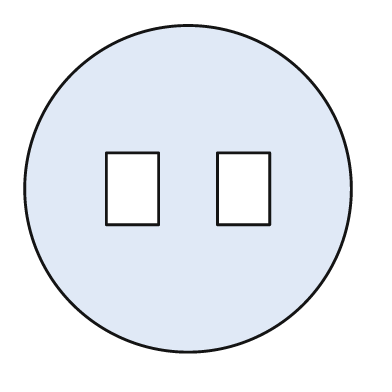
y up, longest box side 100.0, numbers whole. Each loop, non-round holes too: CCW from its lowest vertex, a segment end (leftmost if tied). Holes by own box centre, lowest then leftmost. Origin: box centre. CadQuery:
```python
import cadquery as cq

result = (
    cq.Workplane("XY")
    .moveTo(0.0, 0.0)
    .circle(50.0)
    .moveTo(-25.0, -11.0)
    .lineTo(-9.0, -11.0)
    .lineTo(-9.0, 11.0)
    .lineTo(-25.0, 11.0)
    .close()
    .moveTo(9.0, -11.0)
    .lineTo(25.0, -11.0)
    .lineTo(25.0, 11.0)
    .lineTo(9.0, 11.0)
    .close()
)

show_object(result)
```